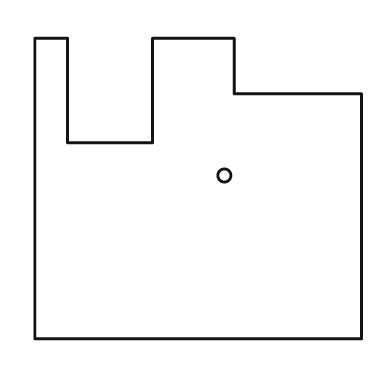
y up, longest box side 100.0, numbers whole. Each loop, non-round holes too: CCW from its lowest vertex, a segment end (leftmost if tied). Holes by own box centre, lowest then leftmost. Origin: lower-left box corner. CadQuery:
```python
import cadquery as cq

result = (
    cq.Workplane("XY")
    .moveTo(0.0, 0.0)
    .lineTo(100.0, 0.0)
    .lineTo(100.0, 75.0)
    .lineTo(61.0, 75.0)
    .lineTo(61.0, 92.0)
    .lineTo(36.0, 92.0)
    .lineTo(36.0, 60.0)
    .lineTo(10.0, 60.0)
    .lineTo(10.0, 92.0)
    .lineTo(0.0, 92.0)
    .close()
    .moveTo(58.0, 50.0)
    .circle(2.0)
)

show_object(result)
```